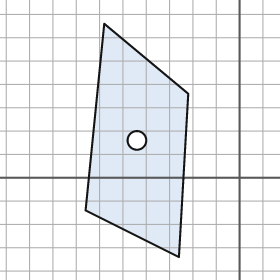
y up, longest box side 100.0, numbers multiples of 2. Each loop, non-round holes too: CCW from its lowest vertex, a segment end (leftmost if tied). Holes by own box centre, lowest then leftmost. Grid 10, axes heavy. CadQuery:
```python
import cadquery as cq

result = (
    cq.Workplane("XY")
    .moveTo(-26.0, -34.0)
    .lineTo(-22.0, 36.0)
    .lineTo(-58.0, 66.0)
    .lineTo(-66.0, -14.0)
    .close()
    .moveTo(-44.0, 16.0)
    .circle(4.0)
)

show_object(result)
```